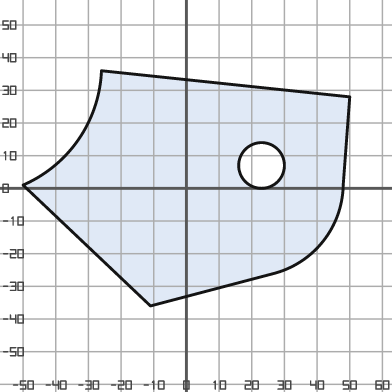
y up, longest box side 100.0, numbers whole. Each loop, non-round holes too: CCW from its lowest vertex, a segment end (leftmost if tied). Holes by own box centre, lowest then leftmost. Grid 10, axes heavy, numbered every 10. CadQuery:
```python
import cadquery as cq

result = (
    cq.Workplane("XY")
    .moveTo(-11.0, -36.0)
    .lineTo(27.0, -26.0)
    .threePointArc((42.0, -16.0), (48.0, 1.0))
    .lineTo(50.0, 28.0)
    .lineTo(-26.0, 36.0)
    .threePointArc((-33.0, 15.0), (-50.0, 1.0))
    .close()
    .moveTo(23.0, 7.0)
    .circle(7.0)
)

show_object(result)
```